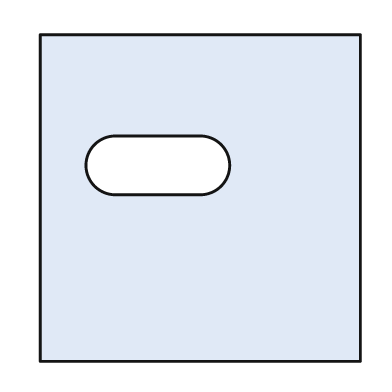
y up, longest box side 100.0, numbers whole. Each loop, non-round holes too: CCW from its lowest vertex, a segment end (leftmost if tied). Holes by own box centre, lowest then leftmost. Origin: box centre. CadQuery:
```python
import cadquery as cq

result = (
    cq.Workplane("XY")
    .moveTo(-49.0, -50.0)
    .lineTo(49.0, -50.0)
    .lineTo(49.0, 50.0)
    .lineTo(-49.0, 50.0)
    .close()
    .moveTo(-26.0, 1.0)
    .lineTo(0.0, 1.0)
    .threePointArc((9.0, 10.0), (0.0, 19.0))
    .lineTo(-26.0, 19.0)
    .threePointArc((-35.0, 10.0), (-26.0, 1.0))
    .close()
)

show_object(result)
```